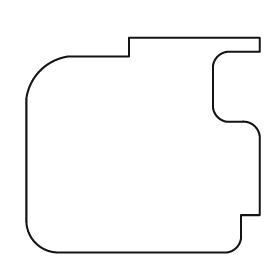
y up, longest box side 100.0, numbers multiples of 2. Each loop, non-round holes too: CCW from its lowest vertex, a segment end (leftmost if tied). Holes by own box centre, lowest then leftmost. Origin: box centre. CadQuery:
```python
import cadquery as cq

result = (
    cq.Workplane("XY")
    .moveTo(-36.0, -46.0)
    .lineTo(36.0, -46.0)
    .threePointArc((40.0, -44.0), (42.0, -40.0))
    .lineTo(42.0, -30.0)
    .lineTo(50.0, -30.0)
    .lineTo(50.0, 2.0)
    .threePointArc((48.0, 8.0), (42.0, 10.0))
    .lineTo(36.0, 10.0)
    .threePointArc((32.0, 12.0), (30.0, 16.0))
    .lineTo(30.0, 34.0)
    .threePointArc((32.0, 38.0), (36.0, 40.0))
    .lineTo(50.0, 40.0)
    .lineTo(50.0, 46.0)
    .lineTo(-6.0, 46.0)
    .lineTo(-6.0, 38.0)
    .lineTo(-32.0, 38.0)
    .threePointArc((-44.0, 32.0), (-50.0, 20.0))
    .lineTo(-50.0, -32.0)
    .threePointArc((-46.0, -42.0), (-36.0, -46.0))
    .close()
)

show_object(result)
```